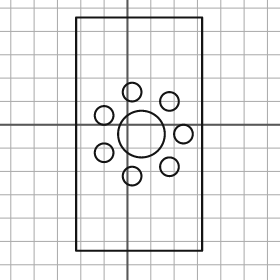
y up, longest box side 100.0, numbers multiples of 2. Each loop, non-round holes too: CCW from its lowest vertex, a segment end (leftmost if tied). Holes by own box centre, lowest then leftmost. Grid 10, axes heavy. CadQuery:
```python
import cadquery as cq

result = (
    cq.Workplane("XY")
    .moveTo(-22.0, -54.0)
    .lineTo(32.0, -54.0)
    .lineTo(32.0, 46.0)
    .lineTo(-22.0, 46.0)
    .close()
    .moveTo(2.0, -22.0)
    .circle(4.0)
    .moveTo(18.0, -18.0)
    .circle(4.0)
    .moveTo(-10.0, -12.0)
    .circle(4.0)
    .moveTo(6.0, -4.0)
    .circle(10.0)
    .moveTo(24.0, -4.0)
    .circle(4.0)
    .moveTo(-10.0, 4.0)
    .circle(4.0)
    .moveTo(18.0, 10.0)
    .circle(4.0)
    .moveTo(2.0, 14.0)
    .circle(4.0)
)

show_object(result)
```